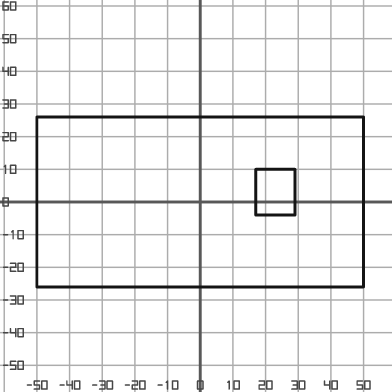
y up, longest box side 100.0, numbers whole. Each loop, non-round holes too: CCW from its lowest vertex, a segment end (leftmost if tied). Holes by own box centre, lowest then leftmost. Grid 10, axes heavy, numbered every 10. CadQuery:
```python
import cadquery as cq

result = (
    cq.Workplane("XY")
    .moveTo(-50.0, -26.0)
    .lineTo(50.0, -26.0)
    .lineTo(50.0, 26.0)
    .lineTo(-50.0, 26.0)
    .close()
    .moveTo(17.0, -4.0)
    .lineTo(29.0, -4.0)
    .lineTo(29.0, 10.0)
    .lineTo(17.0, 10.0)
    .close()
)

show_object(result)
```